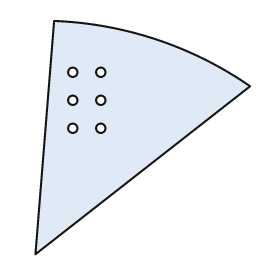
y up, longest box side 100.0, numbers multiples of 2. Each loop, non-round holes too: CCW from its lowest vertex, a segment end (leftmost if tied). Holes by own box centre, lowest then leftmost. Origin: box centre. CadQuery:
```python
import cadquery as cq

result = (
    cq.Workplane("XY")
    .moveTo(-46.0, -50.0)
    .lineTo(46.0, 22.0)
    .threePointArc((6.0, 42.0), (-38.0, 50.0))
    .close()
    .moveTo(-30.0, 4.0)
    .circle(2.0)
    .moveTo(-18.0, 4.0)
    .circle(2.0)
    .moveTo(-30.0, 16.0)
    .circle(2.0)
    .moveTo(-18.0, 16.0)
    .circle(2.0)
    .moveTo(-30.0, 28.0)
    .circle(2.0)
    .moveTo(-18.0, 28.0)
    .circle(2.0)
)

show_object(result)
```